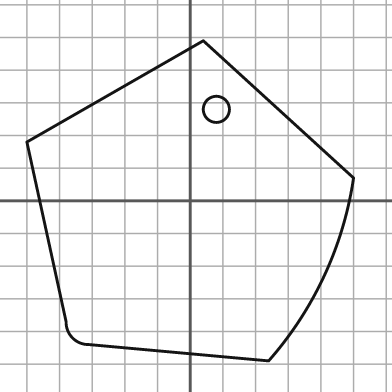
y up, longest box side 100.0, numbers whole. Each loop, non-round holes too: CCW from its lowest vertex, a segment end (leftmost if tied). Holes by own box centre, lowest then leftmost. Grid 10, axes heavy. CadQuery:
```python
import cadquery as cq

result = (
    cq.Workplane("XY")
    .moveTo(24.0, -49.0)
    .threePointArc((41.0, -23.0), (50.0, 7.0))
    .lineTo(4.0, 49.0)
    .lineTo(-50.0, 18.0)
    .lineTo(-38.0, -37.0)
    .threePointArc((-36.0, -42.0), (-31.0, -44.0))
    .close()
    .moveTo(8.0, 28.0)
    .circle(4.0)
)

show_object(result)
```